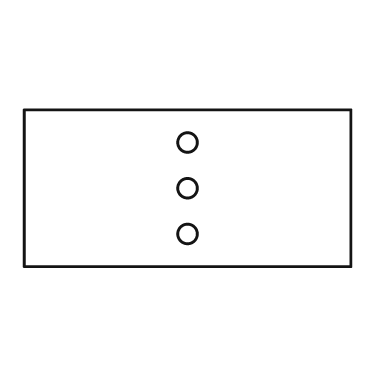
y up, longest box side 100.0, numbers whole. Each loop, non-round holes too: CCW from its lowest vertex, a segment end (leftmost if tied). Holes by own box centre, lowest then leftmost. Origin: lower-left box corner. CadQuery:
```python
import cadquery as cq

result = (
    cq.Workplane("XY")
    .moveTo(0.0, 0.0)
    .lineTo(100.0, 0.0)
    .lineTo(100.0, 48.0)
    .lineTo(0.0, 48.0)
    .close()
    .moveTo(50.0, 10.0)
    .circle(3.0)
    .moveTo(50.0, 24.0)
    .circle(3.0)
    .moveTo(50.0, 38.0)
    .circle(3.0)
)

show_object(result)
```